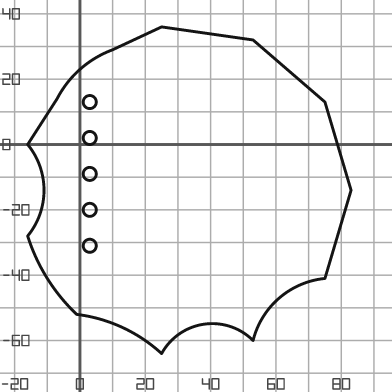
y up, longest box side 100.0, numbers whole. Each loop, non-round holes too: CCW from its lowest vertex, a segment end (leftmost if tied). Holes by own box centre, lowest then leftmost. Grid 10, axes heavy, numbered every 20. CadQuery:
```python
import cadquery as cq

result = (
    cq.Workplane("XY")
    .moveTo(25.0, -64.0)
    .threePointArc((38.0, -55.0), (53.0, -60.0))
    .threePointArc((61.0, -47.0), (75.0, -41.0))
    .lineTo(83.0, -14.0)
    .lineTo(75.0, 13.0)
    .lineTo(53.0, 32.0)
    .lineTo(25.0, 36.0)
    .lineTo(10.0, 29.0)
    .threePointArc((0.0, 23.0), (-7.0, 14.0))
    .lineTo(-16.0, 0.0)
    .threePointArc((-11.0, -14.0), (-16.0, -28.0))
    .threePointArc((-10.0, -41.0), (-1.0, -52.0))
    .threePointArc((13.0, -56.0), (25.0, -64.0))
    .close()
    .moveTo(3.0, -31.0)
    .circle(2.0)
    .moveTo(3.0, -20.0)
    .circle(2.0)
    .moveTo(3.0, -9.0)
    .circle(2.0)
    .moveTo(3.0, 2.0)
    .circle(2.0)
    .moveTo(3.0, 13.0)
    .circle(2.0)
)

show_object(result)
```